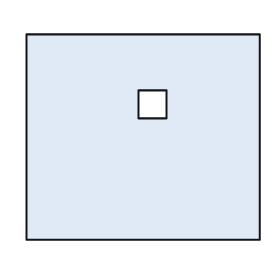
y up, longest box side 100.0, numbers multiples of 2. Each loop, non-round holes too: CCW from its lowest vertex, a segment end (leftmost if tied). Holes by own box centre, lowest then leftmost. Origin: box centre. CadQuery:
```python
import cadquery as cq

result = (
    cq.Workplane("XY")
    .moveTo(-50.0, -44.0)
    .lineTo(50.0, -44.0)
    .lineTo(50.0, 44.0)
    .lineTo(-50.0, 44.0)
    .close()
    .moveTo(-2.0, 8.0)
    .lineTo(10.0, 8.0)
    .lineTo(10.0, 20.0)
    .lineTo(-2.0, 20.0)
    .close()
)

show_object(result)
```